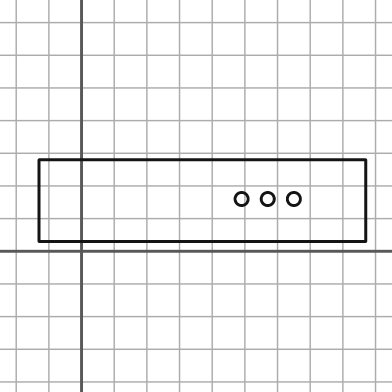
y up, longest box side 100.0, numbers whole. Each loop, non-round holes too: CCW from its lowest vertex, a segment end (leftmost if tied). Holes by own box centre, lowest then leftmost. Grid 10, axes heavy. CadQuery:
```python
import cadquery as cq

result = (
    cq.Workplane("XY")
    .moveTo(-13.0, 3.0)
    .lineTo(87.0, 3.0)
    .lineTo(87.0, 28.0)
    .lineTo(-13.0, 28.0)
    .close()
    .moveTo(49.0, 16.0)
    .circle(2.0)
    .moveTo(57.0, 16.0)
    .circle(2.0)
    .moveTo(65.0, 16.0)
    .circle(2.0)
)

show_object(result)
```